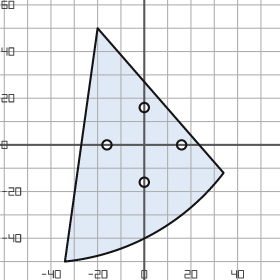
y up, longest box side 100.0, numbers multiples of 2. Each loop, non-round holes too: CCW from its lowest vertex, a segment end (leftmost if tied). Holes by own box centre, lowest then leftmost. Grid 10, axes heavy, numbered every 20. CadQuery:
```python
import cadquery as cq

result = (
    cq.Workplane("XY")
    .moveTo(-34.0, -50.0)
    .threePointArc((4.0, -38.0), (34.0, -12.0))
    .lineTo(-20.0, 50.0)
    .close()
    .moveTo(0.0, -16.0)
    .circle(2.0)
    .moveTo(-16.0, 0.0)
    .circle(2.0)
    .moveTo(16.0, 0.0)
    .circle(2.0)
    .moveTo(0.0, 16.0)
    .circle(2.0)
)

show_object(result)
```